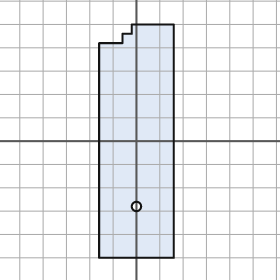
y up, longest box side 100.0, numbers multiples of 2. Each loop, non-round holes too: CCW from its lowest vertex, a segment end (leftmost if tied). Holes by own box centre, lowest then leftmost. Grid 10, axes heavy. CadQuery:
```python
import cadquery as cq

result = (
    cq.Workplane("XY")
    .moveTo(-16.0, -50.0)
    .lineTo(16.0, -50.0)
    .lineTo(16.0, 50.0)
    .lineTo(-2.0, 50.0)
    .lineTo(-2.0, 46.0)
    .lineTo(-6.0, 46.0)
    .lineTo(-6.0, 42.0)
    .lineTo(-16.0, 42.0)
    .close()
    .moveTo(0.0, -28.0)
    .circle(2.0)
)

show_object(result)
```